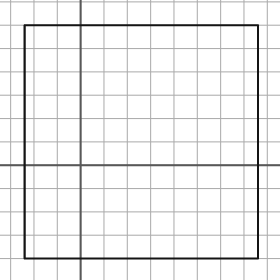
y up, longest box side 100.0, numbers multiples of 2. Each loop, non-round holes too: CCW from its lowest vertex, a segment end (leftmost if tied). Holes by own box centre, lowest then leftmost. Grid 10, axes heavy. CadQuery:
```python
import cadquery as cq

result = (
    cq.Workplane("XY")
    .moveTo(-24.0, -40.0)
    .lineTo(76.0, -40.0)
    .lineTo(76.0, 60.0)
    .lineTo(-24.0, 60.0)
    .close()
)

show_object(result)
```